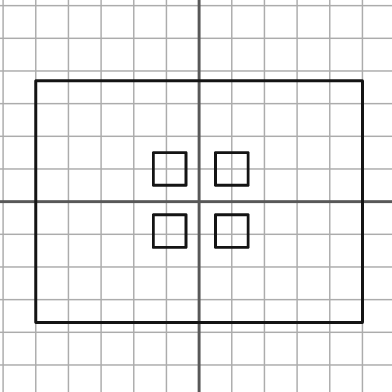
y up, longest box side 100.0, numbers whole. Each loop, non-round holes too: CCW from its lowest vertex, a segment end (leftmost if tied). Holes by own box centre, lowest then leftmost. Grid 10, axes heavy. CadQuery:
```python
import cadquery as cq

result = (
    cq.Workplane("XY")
    .moveTo(-50.0, -37.0)
    .lineTo(50.0, -37.0)
    .lineTo(50.0, 37.0)
    .lineTo(-50.0, 37.0)
    .close()
    .moveTo(-14.0, -14.0)
    .lineTo(-4.0, -14.0)
    .lineTo(-4.0, -4.0)
    .lineTo(-14.0, -4.0)
    .close()
    .moveTo(5.0, -14.0)
    .lineTo(15.0, -14.0)
    .lineTo(15.0, -4.0)
    .lineTo(5.0, -4.0)
    .close()
    .moveTo(-14.0, 5.0)
    .lineTo(-4.0, 5.0)
    .lineTo(-4.0, 15.0)
    .lineTo(-14.0, 15.0)
    .close()
    .moveTo(5.0, 5.0)
    .lineTo(15.0, 5.0)
    .lineTo(15.0, 15.0)
    .lineTo(5.0, 15.0)
    .close()
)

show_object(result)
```